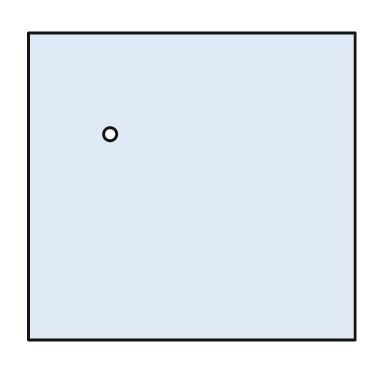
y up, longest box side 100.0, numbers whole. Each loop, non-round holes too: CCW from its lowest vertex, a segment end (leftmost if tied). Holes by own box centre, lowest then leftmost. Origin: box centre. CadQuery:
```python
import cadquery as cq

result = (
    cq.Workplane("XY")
    .moveTo(-50.0, -47.0)
    .lineTo(50.0, -47.0)
    .lineTo(50.0, 47.0)
    .lineTo(-50.0, 47.0)
    .close()
    .moveTo(-25.0, 16.0)
    .circle(2.0)
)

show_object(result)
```